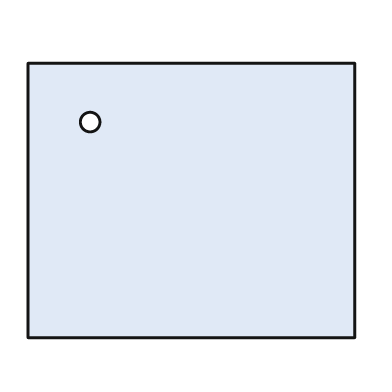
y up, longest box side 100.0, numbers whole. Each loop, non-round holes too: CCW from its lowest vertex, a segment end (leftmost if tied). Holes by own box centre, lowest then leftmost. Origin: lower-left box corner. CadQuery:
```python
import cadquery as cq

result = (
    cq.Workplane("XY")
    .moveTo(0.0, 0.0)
    .lineTo(100.0, 0.0)
    .lineTo(100.0, 84.0)
    .lineTo(0.0, 84.0)
    .close()
    .moveTo(19.0, 66.0)
    .circle(3.0)
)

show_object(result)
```